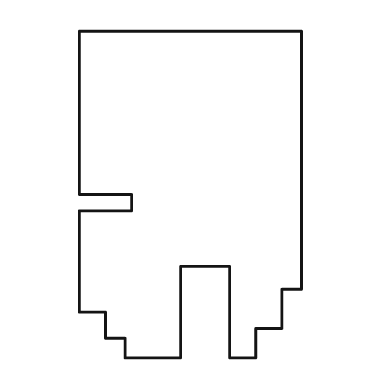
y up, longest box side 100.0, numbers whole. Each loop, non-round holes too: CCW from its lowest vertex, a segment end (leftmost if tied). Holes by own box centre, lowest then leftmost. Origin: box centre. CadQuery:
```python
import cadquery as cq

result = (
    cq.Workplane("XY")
    .moveTo(-20.0, -50.0)
    .lineTo(-3.0, -50.0)
    .lineTo(-3.0, -22.0)
    .lineTo(12.0, -22.0)
    .lineTo(12.0, -50.0)
    .lineTo(20.0, -50.0)
    .lineTo(20.0, -41.0)
    .lineTo(28.0, -41.0)
    .lineTo(28.0, -29.0)
    .lineTo(34.0, -29.0)
    .lineTo(34.0, 50.0)
    .lineTo(-34.0, 50.0)
    .lineTo(-34.0, 0.0)
    .lineTo(-18.0, 0.0)
    .lineTo(-18.0, -5.0)
    .lineTo(-34.0, -5.0)
    .lineTo(-34.0, -36.0)
    .lineTo(-26.0, -36.0)
    .lineTo(-26.0, -44.0)
    .lineTo(-20.0, -44.0)
    .close()
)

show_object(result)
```